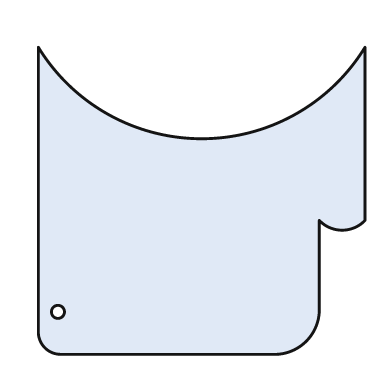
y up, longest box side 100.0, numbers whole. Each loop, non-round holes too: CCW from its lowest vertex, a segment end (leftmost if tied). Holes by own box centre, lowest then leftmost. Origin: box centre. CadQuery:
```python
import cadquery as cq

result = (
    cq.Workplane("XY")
    .moveTo(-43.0, -47.0)
    .lineTo(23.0, -47.0)
    .threePointArc((32.0, -43.0), (36.0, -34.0))
    .lineTo(36.0, -6.0)
    .threePointArc((43.0, -9.0), (50.0, -6.0))
    .lineTo(50.0, 47.0)
    .threePointArc((0.0, 19.0), (-50.0, 47.0))
    .lineTo(-50.0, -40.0)
    .threePointArc((-48.0, -45.0), (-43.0, -47.0))
    .close()
    .moveTo(-44.0, -34.0)
    .circle(2.0)
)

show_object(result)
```